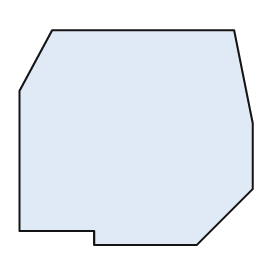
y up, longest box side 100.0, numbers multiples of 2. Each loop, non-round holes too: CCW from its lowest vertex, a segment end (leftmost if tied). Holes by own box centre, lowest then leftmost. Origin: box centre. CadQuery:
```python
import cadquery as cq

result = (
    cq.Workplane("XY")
    .moveTo(-18.0, -46.0)
    .lineTo(26.0, -46.0)
    .lineTo(50.0, -22.0)
    .lineTo(50.0, 6.0)
    .lineTo(42.0, 46.0)
    .lineTo(-36.0, 46.0)
    .lineTo(-50.0, 20.0)
    .lineTo(-50.0, -40.0)
    .lineTo(-18.0, -40.0)
    .close()
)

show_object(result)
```